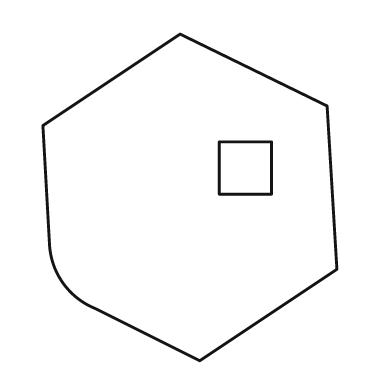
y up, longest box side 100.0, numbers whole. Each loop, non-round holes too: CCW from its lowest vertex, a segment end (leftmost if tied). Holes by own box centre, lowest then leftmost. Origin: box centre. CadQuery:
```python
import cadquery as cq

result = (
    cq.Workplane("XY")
    .moveTo(3.0, -50.0)
    .lineTo(45.0, -22.0)
    .lineTo(42.0, 28.0)
    .lineTo(-3.0, 50.0)
    .lineTo(-45.0, 22.0)
    .lineTo(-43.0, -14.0)
    .threePointArc((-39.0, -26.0), (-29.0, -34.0))
    .close()
    .moveTo(9.0, 1.0)
    .lineTo(25.0, 1.0)
    .lineTo(25.0, 17.0)
    .lineTo(9.0, 17.0)
    .close()
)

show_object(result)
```